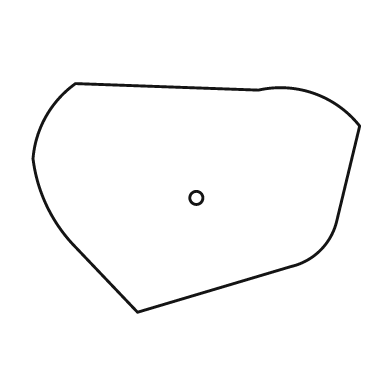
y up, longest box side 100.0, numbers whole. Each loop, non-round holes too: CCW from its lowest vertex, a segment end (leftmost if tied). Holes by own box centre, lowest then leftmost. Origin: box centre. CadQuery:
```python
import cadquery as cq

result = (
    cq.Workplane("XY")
    .moveTo(-18.0, -35.0)
    .lineTo(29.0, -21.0)
    .threePointArc((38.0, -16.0), (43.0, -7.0))
    .lineTo(50.0, 22.0)
    .threePointArc((36.0, 32.0), (19.0, 33.0))
    .lineTo(-37.0, 35.0)
    .threePointArc((-46.0, 25.0), (-50.0, 12.0))
    .threePointArc((-46.0, -2.0), (-38.0, -14.0))
    .close()
    .moveTo(0.0, 0.0)
    .circle(2.0)
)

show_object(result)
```